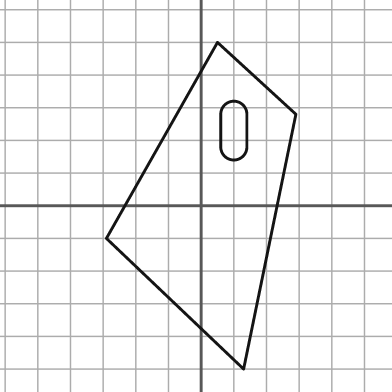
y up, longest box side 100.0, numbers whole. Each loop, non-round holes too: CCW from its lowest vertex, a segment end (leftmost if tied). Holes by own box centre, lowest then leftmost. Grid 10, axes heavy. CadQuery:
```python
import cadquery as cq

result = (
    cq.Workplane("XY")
    .moveTo(13.0, -50.0)
    .lineTo(29.0, 28.0)
    .lineTo(5.0, 50.0)
    .lineTo(-29.0, -10.0)
    .close()
    .moveTo(6.0, 18.0)
    .threePointArc((10.0, 14.0), (14.0, 18.0))
    .lineTo(14.0, 28.0)
    .threePointArc((10.0, 32.0), (6.0, 28.0))
    .close()
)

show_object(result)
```